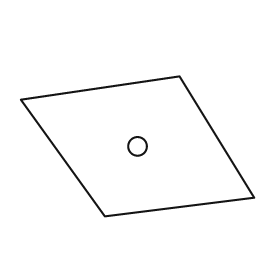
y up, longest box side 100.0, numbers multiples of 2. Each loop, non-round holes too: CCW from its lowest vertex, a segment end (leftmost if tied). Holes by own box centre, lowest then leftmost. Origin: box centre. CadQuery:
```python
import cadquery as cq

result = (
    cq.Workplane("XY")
    .moveTo(-14.0, -30.0)
    .lineTo(50.0, -22.0)
    .lineTo(18.0, 30.0)
    .lineTo(-50.0, 20.0)
    .close()
    .moveTo(0.0, 0.0)
    .circle(4.0)
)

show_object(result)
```